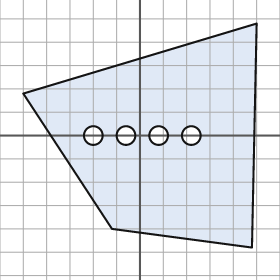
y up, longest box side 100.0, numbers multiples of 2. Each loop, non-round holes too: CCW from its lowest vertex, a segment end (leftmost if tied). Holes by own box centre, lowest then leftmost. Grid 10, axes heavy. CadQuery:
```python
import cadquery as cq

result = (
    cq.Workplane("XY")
    .moveTo(48.0, -48.0)
    .lineTo(50.0, 48.0)
    .lineTo(-50.0, 18.0)
    .lineTo(-12.0, -40.0)
    .close()
    .moveTo(-20.0, 0.0)
    .circle(4.0)
    .moveTo(-6.0, 0.0)
    .circle(4.0)
    .moveTo(8.0, 0.0)
    .circle(4.0)
    .moveTo(22.0, 0.0)
    .circle(4.0)
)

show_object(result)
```